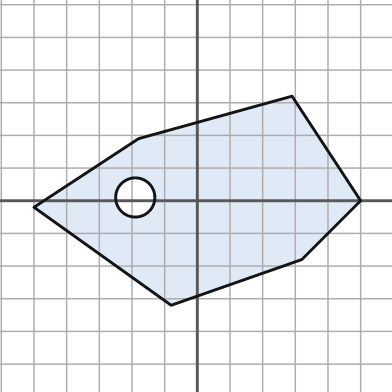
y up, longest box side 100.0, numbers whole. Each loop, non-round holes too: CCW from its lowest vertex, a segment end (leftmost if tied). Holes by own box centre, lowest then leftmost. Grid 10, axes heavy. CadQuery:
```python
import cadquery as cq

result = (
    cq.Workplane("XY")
    .moveTo(-8.0, -32.0)
    .lineTo(32.0, -18.0)
    .lineTo(50.0, 0.0)
    .lineTo(29.0, 32.0)
    .lineTo(-18.0, 19.0)
    .lineTo(-50.0, -2.0)
    .close()
    .moveTo(-19.0, 1.0)
    .circle(6.0)
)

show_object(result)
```